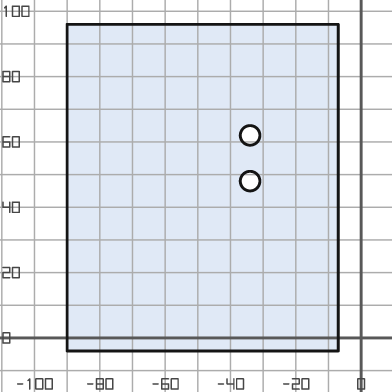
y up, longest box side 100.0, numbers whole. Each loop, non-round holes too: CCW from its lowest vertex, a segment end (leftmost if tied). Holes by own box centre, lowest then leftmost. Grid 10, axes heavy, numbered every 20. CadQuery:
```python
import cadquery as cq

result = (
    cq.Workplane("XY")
    .moveTo(-90.0, -4.0)
    .lineTo(-7.0, -4.0)
    .lineTo(-7.0, 96.0)
    .lineTo(-90.0, 96.0)
    .close()
    .moveTo(-34.0, 48.0)
    .circle(3.0)
    .moveTo(-34.0, 62.0)
    .circle(3.0)
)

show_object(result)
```